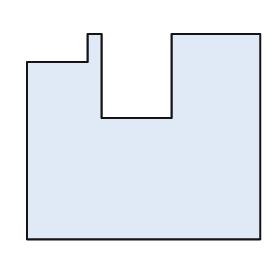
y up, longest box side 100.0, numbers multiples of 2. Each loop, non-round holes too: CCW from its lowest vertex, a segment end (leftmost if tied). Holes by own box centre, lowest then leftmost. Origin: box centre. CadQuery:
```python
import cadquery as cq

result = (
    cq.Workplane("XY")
    .moveTo(-50.0, -44.0)
    .lineTo(50.0, -44.0)
    .lineTo(50.0, 44.0)
    .lineTo(12.0, 44.0)
    .lineTo(12.0, 8.0)
    .lineTo(-18.0, 8.0)
    .lineTo(-18.0, 44.0)
    .lineTo(-24.0, 44.0)
    .lineTo(-24.0, 32.0)
    .lineTo(-50.0, 32.0)
    .close()
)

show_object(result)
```